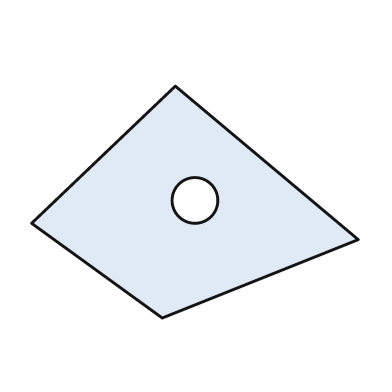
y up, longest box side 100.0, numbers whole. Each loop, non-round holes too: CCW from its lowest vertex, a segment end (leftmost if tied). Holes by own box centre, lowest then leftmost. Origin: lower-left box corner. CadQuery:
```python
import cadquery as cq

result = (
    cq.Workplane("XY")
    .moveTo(40.0, 0.0)
    .lineTo(100.0, 24.0)
    .lineTo(44.0, 71.0)
    .lineTo(0.0, 29.0)
    .close()
    .moveTo(50.0, 36.0)
    .circle(7.0)
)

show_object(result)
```